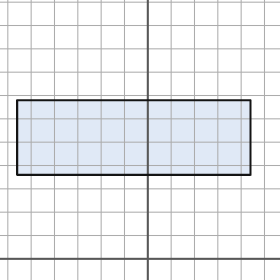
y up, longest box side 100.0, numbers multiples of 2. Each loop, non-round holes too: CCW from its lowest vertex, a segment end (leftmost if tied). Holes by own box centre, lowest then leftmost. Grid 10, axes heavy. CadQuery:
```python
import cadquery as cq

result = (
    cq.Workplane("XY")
    .moveTo(-56.0, 36.0)
    .lineTo(44.0, 36.0)
    .lineTo(44.0, 68.0)
    .lineTo(-56.0, 68.0)
    .close()
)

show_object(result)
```